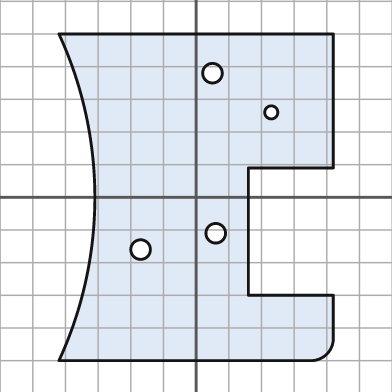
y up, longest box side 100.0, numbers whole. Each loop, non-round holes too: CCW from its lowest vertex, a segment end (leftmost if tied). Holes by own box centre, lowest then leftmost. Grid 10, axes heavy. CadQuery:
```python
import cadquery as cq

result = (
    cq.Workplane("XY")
    .moveTo(-42.0, -50.0)
    .lineTo(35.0, -50.0)
    .threePointArc((40.0, -48.0), (42.0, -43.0))
    .lineTo(42.0, -30.0)
    .lineTo(16.0, -30.0)
    .lineTo(16.0, 9.0)
    .lineTo(42.0, 9.0)
    .lineTo(42.0, 50.0)
    .lineTo(-42.0, 50.0)
    .threePointArc((-31.0, 0.0), (-42.0, -50.0))
    .close()
    .moveTo(-17.0, -16.0)
    .circle(3.0)
    .moveTo(6.0, -11.0)
    .circle(3.0)
    .moveTo(23.0, 26.0)
    .circle(2.0)
    .moveTo(5.0, 38.0)
    .circle(3.0)
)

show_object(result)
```